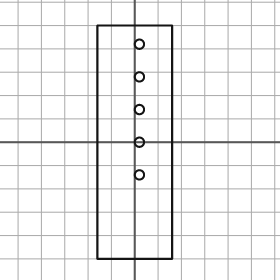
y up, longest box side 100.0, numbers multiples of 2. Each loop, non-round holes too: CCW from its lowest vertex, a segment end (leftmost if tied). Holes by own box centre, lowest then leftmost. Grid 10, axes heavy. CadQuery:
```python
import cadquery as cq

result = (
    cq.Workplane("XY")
    .moveTo(-16.0, -50.0)
    .lineTo(16.0, -50.0)
    .lineTo(16.0, 50.0)
    .lineTo(-16.0, 50.0)
    .close()
    .moveTo(2.0, -14.0)
    .circle(2.0)
    .moveTo(2.0, 0.0)
    .circle(2.0)
    .moveTo(2.0, 14.0)
    .circle(2.0)
    .moveTo(2.0, 28.0)
    .circle(2.0)
    .moveTo(2.0, 42.0)
    .circle(2.0)
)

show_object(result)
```